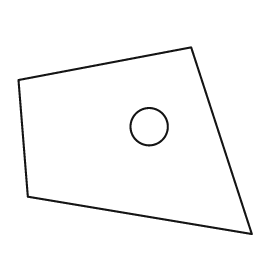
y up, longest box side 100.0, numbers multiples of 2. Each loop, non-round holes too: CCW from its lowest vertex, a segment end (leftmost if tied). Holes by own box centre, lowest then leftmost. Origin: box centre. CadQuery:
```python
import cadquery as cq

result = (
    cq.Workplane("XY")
    .moveTo(50.0, -40.0)
    .lineTo(24.0, 40.0)
    .lineTo(-50.0, 26.0)
    .lineTo(-46.0, -24.0)
    .close()
    .moveTo(6.0, 6.0)
    .circle(8.0)
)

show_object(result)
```